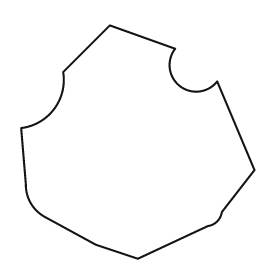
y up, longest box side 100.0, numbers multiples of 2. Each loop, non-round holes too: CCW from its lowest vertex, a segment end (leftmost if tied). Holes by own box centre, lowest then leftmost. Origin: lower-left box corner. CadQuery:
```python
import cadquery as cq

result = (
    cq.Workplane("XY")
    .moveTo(50.0, 0.0)
    .lineTo(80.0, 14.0)
    .threePointArc((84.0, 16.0), (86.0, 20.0))
    .lineTo(100.0, 38.0)
    .lineTo(84.0, 76.0)
    .threePointArc((68.0, 74.0), (66.0, 90.0))
    .lineTo(38.0, 100.0)
    .lineTo(18.0, 80.0)
    .threePointArc((14.0, 64.0), (0.0, 56.0))
    .lineTo(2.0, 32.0)
    .threePointArc((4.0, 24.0), (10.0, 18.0))
    .lineTo(32.0, 6.0)
    .close()
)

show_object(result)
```